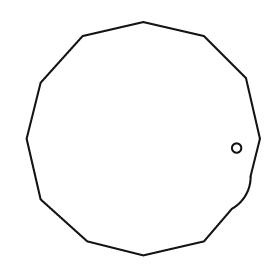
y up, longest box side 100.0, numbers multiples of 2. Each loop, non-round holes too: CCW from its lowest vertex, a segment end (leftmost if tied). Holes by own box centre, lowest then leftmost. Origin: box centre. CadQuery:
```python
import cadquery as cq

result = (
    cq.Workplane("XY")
    .moveTo(0.0, -50.0)
    .lineTo(26.0, -44.0)
    .lineTo(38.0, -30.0)
    .threePointArc((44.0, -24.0), (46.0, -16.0))
    .lineTo(50.0, 0.0)
    .lineTo(44.0, 26.0)
    .lineTo(26.0, 44.0)
    .lineTo(0.0, 50.0)
    .lineTo(-26.0, 44.0)
    .lineTo(-44.0, 24.0)
    .lineTo(-50.0, 0.0)
    .lineTo(-44.0, -26.0)
    .lineTo(-24.0, -44.0)
    .close()
    .moveTo(40.0, -4.0)
    .circle(2.0)
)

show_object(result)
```